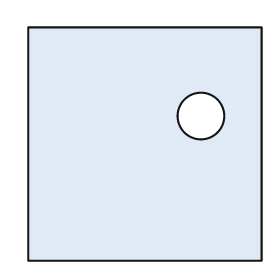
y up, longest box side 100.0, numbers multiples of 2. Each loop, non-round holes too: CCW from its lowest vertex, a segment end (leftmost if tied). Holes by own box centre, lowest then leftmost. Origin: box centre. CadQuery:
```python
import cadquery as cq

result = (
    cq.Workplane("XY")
    .moveTo(-50.0, -50.0)
    .lineTo(50.0, -50.0)
    .lineTo(50.0, 50.0)
    .lineTo(-50.0, 50.0)
    .close()
    .moveTo(24.0, 12.0)
    .circle(10.0)
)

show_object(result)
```